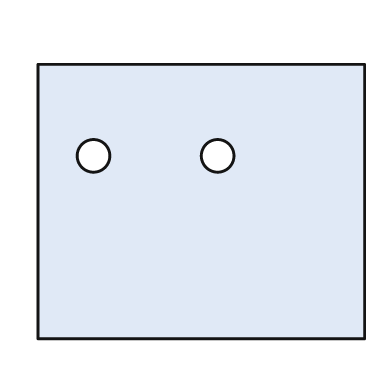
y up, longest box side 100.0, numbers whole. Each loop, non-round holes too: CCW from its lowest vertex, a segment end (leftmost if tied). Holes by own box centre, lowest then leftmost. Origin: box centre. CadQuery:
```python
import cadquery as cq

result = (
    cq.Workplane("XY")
    .moveTo(-50.0, -42.0)
    .lineTo(50.0, -42.0)
    .lineTo(50.0, 42.0)
    .lineTo(-50.0, 42.0)
    .close()
    .moveTo(-33.0, 14.0)
    .circle(5.0)
    .moveTo(5.0, 14.0)
    .circle(5.0)
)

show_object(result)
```